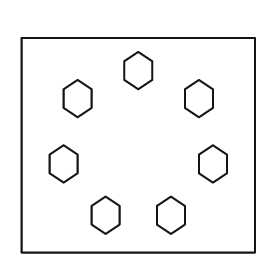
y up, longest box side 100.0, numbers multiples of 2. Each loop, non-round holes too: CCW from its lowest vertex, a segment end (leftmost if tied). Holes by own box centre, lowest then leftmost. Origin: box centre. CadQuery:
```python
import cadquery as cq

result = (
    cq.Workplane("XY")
    .moveTo(-50.0, -46.0)
    .lineTo(50.0, -46.0)
    .lineTo(50.0, 46.0)
    .lineTo(-50.0, 46.0)
    .close()
    .moveTo(-14.0, -38.0)
    .lineTo(-8.0, -34.0)
    .lineTo(-8.0, -26.0)
    .lineTo(-14.0, -22.0)
    .lineTo(-20.0, -26.0)
    .lineTo(-20.0, -34.0)
    .close()
    .moveTo(14.0, -38.0)
    .lineTo(20.0, -34.0)
    .lineTo(20.0, -26.0)
    .lineTo(14.0, -22.0)
    .lineTo(8.0, -26.0)
    .lineTo(8.0, -34.0)
    .close()
    .moveTo(-32.0, -16.0)
    .lineTo(-26.0, -12.0)
    .lineTo(-26.0, -4.0)
    .lineTo(-32.0, 0.0)
    .lineTo(-38.0, -4.0)
    .lineTo(-38.0, -12.0)
    .close()
    .moveTo(32.0, -16.0)
    .lineTo(38.0, -12.0)
    .lineTo(38.0, -4.0)
    .lineTo(32.0, 0.0)
    .lineTo(26.0, -4.0)
    .lineTo(26.0, -12.0)
    .close()
    .moveTo(-26.0, 12.0)
    .lineTo(-20.0, 16.0)
    .lineTo(-20.0, 24.0)
    .lineTo(-26.0, 28.0)
    .lineTo(-32.0, 24.0)
    .lineTo(-32.0, 16.0)
    .close()
    .moveTo(26.0, 12.0)
    .lineTo(32.0, 16.0)
    .lineTo(32.0, 24.0)
    .lineTo(26.0, 28.0)
    .lineTo(20.0, 24.0)
    .lineTo(20.0, 16.0)
    .close()
    .moveTo(0.0, 24.0)
    .lineTo(6.0, 28.0)
    .lineTo(6.0, 36.0)
    .lineTo(0.0, 40.0)
    .lineTo(-6.0, 36.0)
    .lineTo(-6.0, 28.0)
    .close()
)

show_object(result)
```